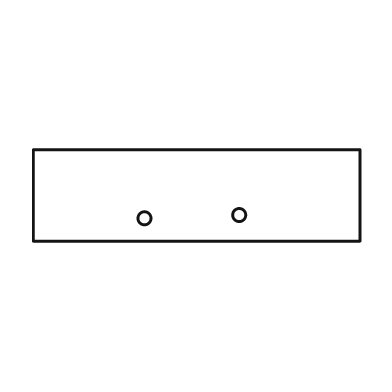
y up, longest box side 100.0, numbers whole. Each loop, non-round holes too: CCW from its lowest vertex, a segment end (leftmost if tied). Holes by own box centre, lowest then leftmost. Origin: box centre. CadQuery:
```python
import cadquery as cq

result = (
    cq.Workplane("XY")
    .moveTo(-50.0, -14.0)
    .lineTo(50.0, -14.0)
    .lineTo(50.0, 14.0)
    .lineTo(-50.0, 14.0)
    .close()
    .moveTo(-16.0, -7.0)
    .circle(2.0)
    .moveTo(13.0, -6.0)
    .circle(2.0)
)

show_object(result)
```